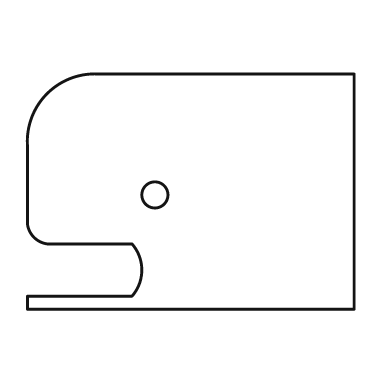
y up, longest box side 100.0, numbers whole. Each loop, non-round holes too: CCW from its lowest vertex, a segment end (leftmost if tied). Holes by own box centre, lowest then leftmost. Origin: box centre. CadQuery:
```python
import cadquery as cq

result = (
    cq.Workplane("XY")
    .moveTo(-50.0, -36.0)
    .lineTo(50.0, -36.0)
    .lineTo(50.0, 36.0)
    .lineTo(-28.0, 36.0)
    .threePointArc((-44.0, 30.0), (-50.0, 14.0))
    .lineTo(-50.0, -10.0)
    .threePointArc((-48.0, -14.0), (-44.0, -16.0))
    .lineTo(-18.0, -16.0)
    .threePointArc((-15.0, -24.0), (-18.0, -32.0))
    .lineTo(-50.0, -32.0)
    .close()
    .moveTo(-11.0, -1.0)
    .circle(4.0)
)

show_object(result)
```